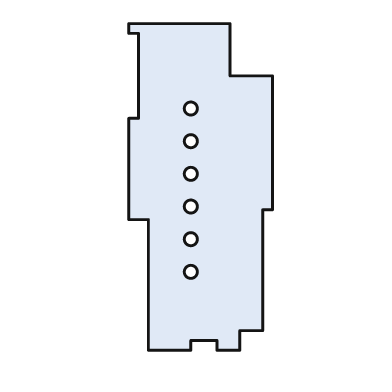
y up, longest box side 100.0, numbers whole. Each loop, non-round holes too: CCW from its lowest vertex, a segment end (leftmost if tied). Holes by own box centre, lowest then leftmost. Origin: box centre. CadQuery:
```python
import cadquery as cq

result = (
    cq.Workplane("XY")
    .moveTo(-16.0, -50.0)
    .lineTo(-3.0, -50.0)
    .lineTo(-3.0, -47.0)
    .lineTo(5.0, -47.0)
    .lineTo(5.0, -50.0)
    .lineTo(12.0, -50.0)
    .lineTo(12.0, -44.0)
    .lineTo(19.0, -44.0)
    .lineTo(19.0, -7.0)
    .lineTo(22.0, -7.0)
    .lineTo(22.0, 34.0)
    .lineTo(9.0, 34.0)
    .lineTo(9.0, 50.0)
    .lineTo(-22.0, 50.0)
    .lineTo(-22.0, 47.0)
    .lineTo(-19.0, 47.0)
    .lineTo(-19.0, 21.0)
    .lineTo(-22.0, 21.0)
    .lineTo(-22.0, -10.0)
    .lineTo(-16.0, -10.0)
    .close()
    .moveTo(-3.0, -26.0)
    .circle(2.0)
    .moveTo(-3.0, -16.0)
    .circle(2.0)
    .moveTo(-3.0, -6.0)
    .circle(2.0)
    .moveTo(-3.0, 4.0)
    .circle(2.0)
    .moveTo(-3.0, 14.0)
    .circle(2.0)
    .moveTo(-3.0, 24.0)
    .circle(2.0)
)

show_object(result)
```